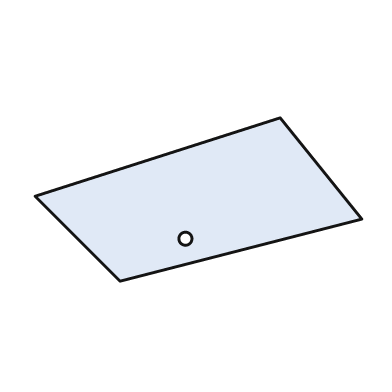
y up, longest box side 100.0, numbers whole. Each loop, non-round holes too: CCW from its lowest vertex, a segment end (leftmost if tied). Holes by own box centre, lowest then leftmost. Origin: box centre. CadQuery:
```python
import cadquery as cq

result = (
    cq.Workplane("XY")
    .moveTo(-24.0, -25.0)
    .lineTo(50.0, -6.0)
    .lineTo(25.0, 25.0)
    .lineTo(-50.0, 1.0)
    .close()
    .moveTo(-4.0, -12.0)
    .circle(2.0)
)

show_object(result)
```